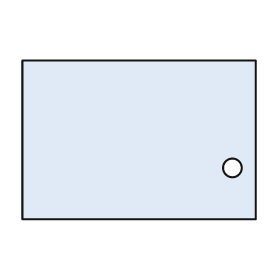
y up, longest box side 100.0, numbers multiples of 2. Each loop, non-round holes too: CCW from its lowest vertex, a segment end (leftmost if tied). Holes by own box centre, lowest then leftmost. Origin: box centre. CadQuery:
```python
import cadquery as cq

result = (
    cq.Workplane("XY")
    .moveTo(-50.0, -34.0)
    .lineTo(50.0, -34.0)
    .lineTo(50.0, 34.0)
    .lineTo(-50.0, 34.0)
    .close()
    .moveTo(40.0, -12.0)
    .circle(4.0)
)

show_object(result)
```